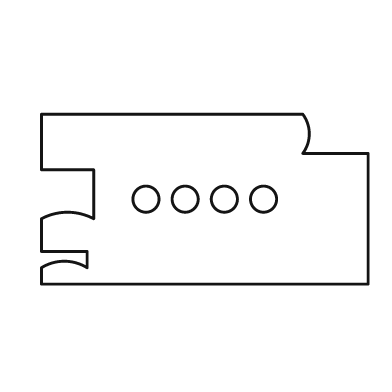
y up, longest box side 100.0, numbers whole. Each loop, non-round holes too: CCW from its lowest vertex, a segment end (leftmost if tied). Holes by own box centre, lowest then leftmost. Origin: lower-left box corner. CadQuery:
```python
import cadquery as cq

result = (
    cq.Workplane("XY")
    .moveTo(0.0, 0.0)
    .lineTo(100.0, 0.0)
    .lineTo(100.0, 40.0)
    .lineTo(80.0, 40.0)
    .threePointArc((82.0, 46.0), (80.0, 52.0))
    .lineTo(0.0, 52.0)
    .lineTo(0.0, 35.0)
    .lineTo(16.0, 35.0)
    .lineTo(16.0, 20.0)
    .threePointArc((8.0, 22.0), (0.0, 20.0))
    .lineTo(0.0, 10.0)
    .lineTo(14.0, 10.0)
    .lineTo(14.0, 5.0)
    .threePointArc((7.0, 7.0), (0.0, 5.0))
    .close()
    .moveTo(32.0, 26.0)
    .circle(4.0)
    .moveTo(44.0, 26.0)
    .circle(4.0)
    .moveTo(56.0, 26.0)
    .circle(4.0)
    .moveTo(68.0, 26.0)
    .circle(4.0)
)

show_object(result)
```